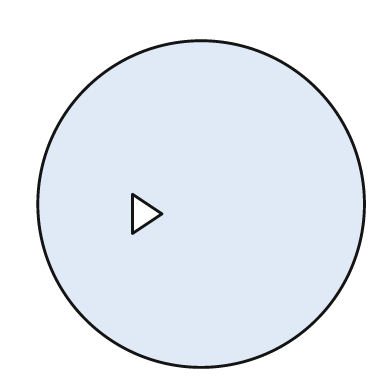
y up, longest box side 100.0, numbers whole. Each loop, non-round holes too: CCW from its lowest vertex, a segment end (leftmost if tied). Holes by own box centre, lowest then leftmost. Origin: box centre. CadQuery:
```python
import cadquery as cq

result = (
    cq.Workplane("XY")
    .moveTo(0.0, 0.0)
    .circle(50.0)
    .moveTo(-21.0, -9.0)
    .lineTo(-12.0, -3.0)
    .lineTo(-21.0, 3.0)
    .close()
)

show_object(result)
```